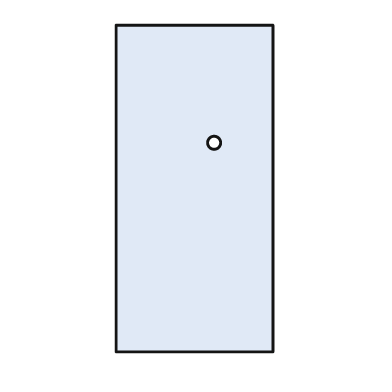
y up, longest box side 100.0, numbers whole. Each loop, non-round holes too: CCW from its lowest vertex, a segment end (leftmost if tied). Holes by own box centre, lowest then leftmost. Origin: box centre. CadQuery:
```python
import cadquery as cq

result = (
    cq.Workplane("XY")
    .moveTo(-24.0, -50.0)
    .lineTo(24.0, -50.0)
    .lineTo(24.0, 50.0)
    .lineTo(-24.0, 50.0)
    .close()
    .moveTo(6.0, 14.0)
    .circle(2.0)
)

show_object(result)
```